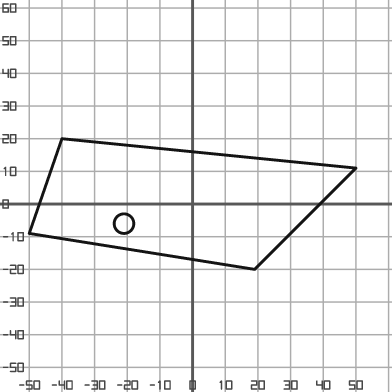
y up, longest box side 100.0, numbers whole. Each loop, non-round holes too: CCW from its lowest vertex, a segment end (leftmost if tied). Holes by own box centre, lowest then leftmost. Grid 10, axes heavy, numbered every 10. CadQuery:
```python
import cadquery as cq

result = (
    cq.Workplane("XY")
    .moveTo(19.0, -20.0)
    .lineTo(50.0, 11.0)
    .lineTo(-40.0, 20.0)
    .lineTo(-50.0, -9.0)
    .close()
    .moveTo(-21.0, -6.0)
    .circle(3.0)
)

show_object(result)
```